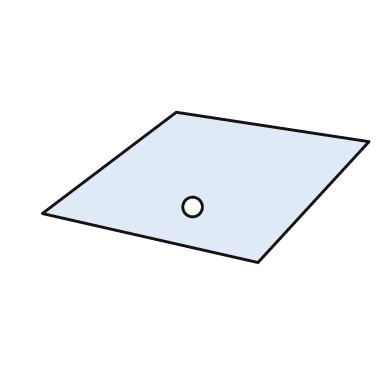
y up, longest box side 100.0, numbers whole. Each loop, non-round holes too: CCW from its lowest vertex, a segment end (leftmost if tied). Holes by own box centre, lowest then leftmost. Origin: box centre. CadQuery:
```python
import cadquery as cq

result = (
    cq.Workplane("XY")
    .moveTo(16.0, -23.0)
    .lineTo(50.0, 14.0)
    .lineTo(-9.0, 23.0)
    .lineTo(-50.0, -8.0)
    .close()
    .moveTo(-4.0, -6.0)
    .circle(3.0)
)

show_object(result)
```